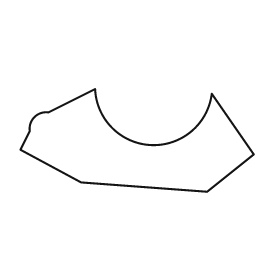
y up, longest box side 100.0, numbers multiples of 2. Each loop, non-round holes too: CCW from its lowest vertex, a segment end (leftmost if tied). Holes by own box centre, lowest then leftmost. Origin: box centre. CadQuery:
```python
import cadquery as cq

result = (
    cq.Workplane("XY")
    .moveTo(30.0, -22.0)
    .lineTo(50.0, -6.0)
    .lineTo(32.0, 20.0)
    .threePointArc((6.0, -2.0), (-18.0, 22.0))
    .lineTo(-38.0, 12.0)
    .threePointArc((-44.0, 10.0), (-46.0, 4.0))
    .lineTo(-50.0, -4.0)
    .lineTo(-24.0, -18.0)
    .close()
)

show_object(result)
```